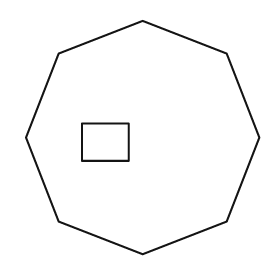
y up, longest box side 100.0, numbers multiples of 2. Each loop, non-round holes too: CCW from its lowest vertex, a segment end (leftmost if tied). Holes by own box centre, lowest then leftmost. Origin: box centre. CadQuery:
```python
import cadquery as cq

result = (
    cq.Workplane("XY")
    .moveTo(0.0, -50.0)
    .lineTo(36.0, -36.0)
    .lineTo(50.0, 0.0)
    .lineTo(36.0, 36.0)
    .lineTo(0.0, 50.0)
    .lineTo(-36.0, 36.0)
    .lineTo(-50.0, 0.0)
    .lineTo(-36.0, -36.0)
    .close()
    .moveTo(-26.0, -10.0)
    .lineTo(-6.0, -10.0)
    .lineTo(-6.0, 6.0)
    .lineTo(-26.0, 6.0)
    .close()
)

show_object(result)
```